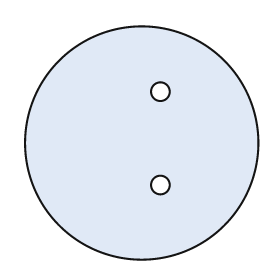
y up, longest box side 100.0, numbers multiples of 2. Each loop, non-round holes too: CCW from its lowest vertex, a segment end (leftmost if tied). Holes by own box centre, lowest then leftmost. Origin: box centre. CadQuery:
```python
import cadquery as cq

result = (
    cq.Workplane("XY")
    .moveTo(0.0, 0.0)
    .circle(50.0)
    .moveTo(8.0, -18.0)
    .circle(4.0)
    .moveTo(8.0, 22.0)
    .circle(4.0)
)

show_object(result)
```